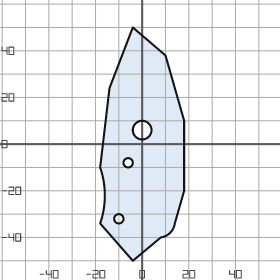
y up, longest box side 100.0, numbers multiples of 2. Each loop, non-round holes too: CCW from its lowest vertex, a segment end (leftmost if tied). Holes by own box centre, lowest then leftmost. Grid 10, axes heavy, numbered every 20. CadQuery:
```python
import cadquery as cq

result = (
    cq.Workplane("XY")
    .moveTo(-4.0, -50.0)
    .lineTo(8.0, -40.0)
    .threePointArc((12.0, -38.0), (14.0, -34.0))
    .lineTo(18.0, -20.0)
    .lineTo(18.0, 10.0)
    .lineTo(10.0, 38.0)
    .lineTo(-4.0, 50.0)
    .lineTo(-14.0, 24.0)
    .lineTo(-18.0, -10.0)
    .threePointArc((-16.0, -22.0), (-18.0, -34.0))
    .close()
    .moveTo(-10.0, -32.0)
    .circle(2.0)
    .moveTo(-6.0, -8.0)
    .circle(2.0)
    .moveTo(0.0, 6.0)
    .circle(4.0)
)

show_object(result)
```